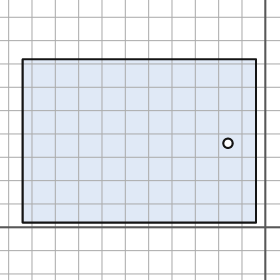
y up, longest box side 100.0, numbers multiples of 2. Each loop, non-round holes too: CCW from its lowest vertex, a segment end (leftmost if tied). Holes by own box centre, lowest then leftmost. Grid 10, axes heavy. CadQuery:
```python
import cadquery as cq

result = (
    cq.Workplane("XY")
    .moveTo(-104.0, 2.0)
    .lineTo(-4.0, 2.0)
    .lineTo(-4.0, 72.0)
    .lineTo(-104.0, 72.0)
    .close()
    .moveTo(-16.0, 36.0)
    .circle(2.0)
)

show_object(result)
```